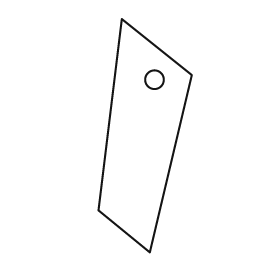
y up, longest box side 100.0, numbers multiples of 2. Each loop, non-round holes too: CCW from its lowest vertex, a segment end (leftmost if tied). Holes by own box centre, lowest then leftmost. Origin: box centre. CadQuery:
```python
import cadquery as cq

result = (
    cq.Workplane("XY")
    .moveTo(2.0, -50.0)
    .lineTo(20.0, 26.0)
    .lineTo(-10.0, 50.0)
    .lineTo(-20.0, -32.0)
    .close()
    .moveTo(4.0, 24.0)
    .circle(4.0)
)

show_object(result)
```